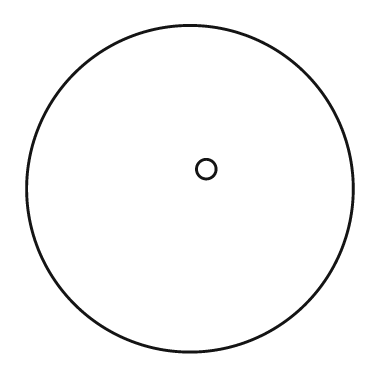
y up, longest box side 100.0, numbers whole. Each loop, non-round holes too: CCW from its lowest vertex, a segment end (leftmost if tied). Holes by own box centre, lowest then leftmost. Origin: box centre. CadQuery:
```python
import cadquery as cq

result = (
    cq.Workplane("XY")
    .moveTo(0.0, 0.0)
    .circle(50.0)
    .moveTo(5.0, 6.0)
    .circle(3.0)
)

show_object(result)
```